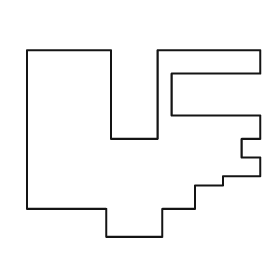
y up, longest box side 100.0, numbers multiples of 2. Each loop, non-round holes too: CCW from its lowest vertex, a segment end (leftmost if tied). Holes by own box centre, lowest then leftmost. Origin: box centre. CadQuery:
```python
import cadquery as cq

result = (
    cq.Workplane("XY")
    .moveTo(-16.0, -40.0)
    .lineTo(8.0, -40.0)
    .lineTo(8.0, -28.0)
    .lineTo(22.0, -28.0)
    .lineTo(22.0, -18.0)
    .lineTo(34.0, -18.0)
    .lineTo(34.0, -14.0)
    .lineTo(50.0, -14.0)
    .lineTo(50.0, -6.0)
    .lineTo(42.0, -6.0)
    .lineTo(42.0, 2.0)
    .lineTo(50.0, 2.0)
    .lineTo(50.0, 12.0)
    .lineTo(12.0, 12.0)
    .lineTo(12.0, 30.0)
    .lineTo(50.0, 30.0)
    .lineTo(50.0, 40.0)
    .lineTo(6.0, 40.0)
    .lineTo(6.0, 2.0)
    .lineTo(-14.0, 2.0)
    .lineTo(-14.0, 40.0)
    .lineTo(-50.0, 40.0)
    .lineTo(-50.0, -28.0)
    .lineTo(-16.0, -28.0)
    .close()
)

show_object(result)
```